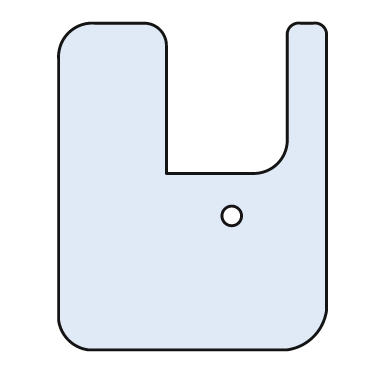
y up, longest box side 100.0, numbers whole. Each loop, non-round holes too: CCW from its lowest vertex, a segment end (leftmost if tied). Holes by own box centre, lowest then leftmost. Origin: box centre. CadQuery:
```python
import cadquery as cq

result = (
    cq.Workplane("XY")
    .moveTo(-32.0, -50.0)
    .lineTo(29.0, -50.0)
    .threePointArc((37.0, -46.0), (41.0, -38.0))
    .lineTo(41.0, 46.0)
    .threePointArc((40.0, 49.0), (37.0, 50.0))
    .lineTo(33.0, 50.0)
    .threePointArc((30.0, 49.0), (29.0, 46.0))
    .lineTo(29.0, 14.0)
    .threePointArc((26.0, 7.0), (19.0, 4.0))
    .lineTo(-8.0, 4.0)
    .lineTo(-8.0, 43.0)
    .threePointArc((-10.0, 48.0), (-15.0, 50.0))
    .lineTo(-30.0, 50.0)
    .threePointArc((-38.0, 47.0), (-41.0, 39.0))
    .lineTo(-41.0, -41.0)
    .threePointArc((-38.0, -47.0), (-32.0, -50.0))
    .close()
    .moveTo(12.0, -9.0)
    .circle(3.0)
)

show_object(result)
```